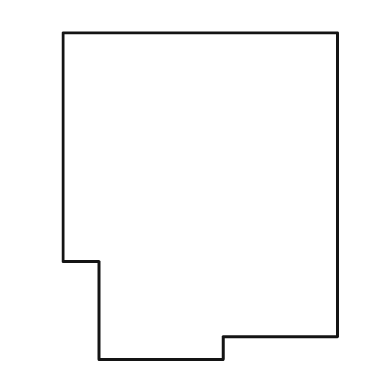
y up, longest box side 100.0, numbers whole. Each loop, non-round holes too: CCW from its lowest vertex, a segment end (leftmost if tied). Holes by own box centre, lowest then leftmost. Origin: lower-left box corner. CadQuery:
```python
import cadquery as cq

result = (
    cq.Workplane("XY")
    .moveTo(11.0, 0.0)
    .lineTo(49.0, 0.0)
    .lineTo(49.0, 7.0)
    .lineTo(84.0, 7.0)
    .lineTo(84.0, 100.0)
    .lineTo(0.0, 100.0)
    .lineTo(0.0, 30.0)
    .lineTo(11.0, 30.0)
    .close()
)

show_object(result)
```